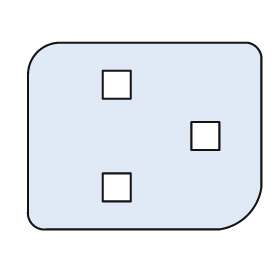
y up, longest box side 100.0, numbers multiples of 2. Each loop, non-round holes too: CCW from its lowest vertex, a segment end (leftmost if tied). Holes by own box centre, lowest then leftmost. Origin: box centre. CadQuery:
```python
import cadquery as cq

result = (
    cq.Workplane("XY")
    .moveTo(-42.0, -40.0)
    .lineTo(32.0, -40.0)
    .threePointArc((44.0, -34.0), (50.0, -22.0))
    .lineTo(50.0, 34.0)
    .threePointArc((48.0, 38.0), (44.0, 40.0))
    .lineTo(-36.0, 40.0)
    .threePointArc((-46.0, 36.0), (-50.0, 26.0))
    .lineTo(-50.0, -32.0)
    .threePointArc((-48.0, -38.0), (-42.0, -40.0))
    .close()
    .moveTo(-18.0, -28.0)
    .lineTo(-6.0, -28.0)
    .lineTo(-6.0, -16.0)
    .lineTo(-18.0, -16.0)
    .close()
    .moveTo(20.0, -6.0)
    .lineTo(32.0, -6.0)
    .lineTo(32.0, 6.0)
    .lineTo(20.0, 6.0)
    .close()
    .moveTo(-18.0, 16.0)
    .lineTo(-6.0, 16.0)
    .lineTo(-6.0, 28.0)
    .lineTo(-18.0, 28.0)
    .close()
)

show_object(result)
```